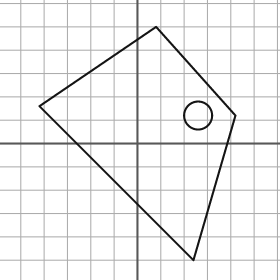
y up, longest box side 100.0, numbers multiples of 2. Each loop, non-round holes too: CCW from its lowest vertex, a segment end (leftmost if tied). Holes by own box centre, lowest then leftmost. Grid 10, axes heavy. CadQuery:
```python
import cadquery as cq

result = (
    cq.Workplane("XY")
    .moveTo(24.0, -50.0)
    .lineTo(42.0, 12.0)
    .lineTo(8.0, 50.0)
    .lineTo(-42.0, 16.0)
    .close()
    .moveTo(26.0, 12.0)
    .circle(6.0)
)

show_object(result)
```